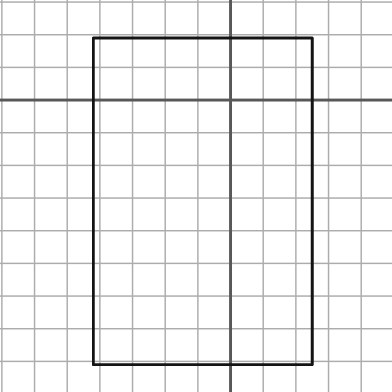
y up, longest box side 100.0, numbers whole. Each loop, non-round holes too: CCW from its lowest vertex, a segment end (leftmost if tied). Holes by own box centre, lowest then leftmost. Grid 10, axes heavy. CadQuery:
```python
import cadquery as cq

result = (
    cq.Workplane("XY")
    .moveTo(-42.0, -81.0)
    .lineTo(25.0, -81.0)
    .lineTo(25.0, 19.0)
    .lineTo(-42.0, 19.0)
    .close()
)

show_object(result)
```